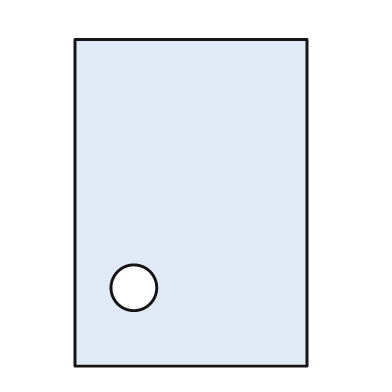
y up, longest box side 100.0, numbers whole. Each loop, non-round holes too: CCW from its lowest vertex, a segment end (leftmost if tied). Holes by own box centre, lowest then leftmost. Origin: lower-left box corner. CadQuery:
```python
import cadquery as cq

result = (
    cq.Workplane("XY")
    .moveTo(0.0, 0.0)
    .lineTo(71.0, 0.0)
    .lineTo(71.0, 100.0)
    .lineTo(0.0, 100.0)
    .close()
    .moveTo(18.0, 24.0)
    .circle(7.0)
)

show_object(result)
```